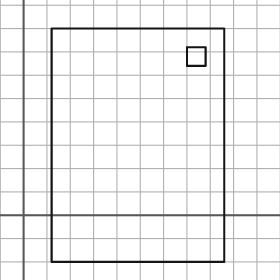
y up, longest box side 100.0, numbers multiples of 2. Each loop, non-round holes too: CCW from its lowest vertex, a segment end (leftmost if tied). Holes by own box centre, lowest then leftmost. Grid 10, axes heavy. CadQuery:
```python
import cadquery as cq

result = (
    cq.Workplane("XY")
    .moveTo(12.0, -20.0)
    .lineTo(86.0, -20.0)
    .lineTo(86.0, 80.0)
    .lineTo(12.0, 80.0)
    .close()
    .moveTo(70.0, 64.0)
    .lineTo(78.0, 64.0)
    .lineTo(78.0, 72.0)
    .lineTo(70.0, 72.0)
    .close()
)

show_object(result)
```